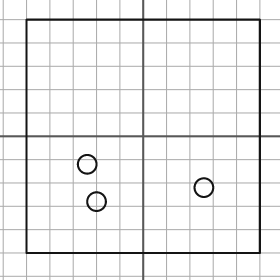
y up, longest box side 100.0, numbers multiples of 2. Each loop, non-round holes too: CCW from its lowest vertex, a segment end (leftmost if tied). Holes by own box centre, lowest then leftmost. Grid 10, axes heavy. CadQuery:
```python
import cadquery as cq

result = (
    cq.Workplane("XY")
    .moveTo(-50.0, -50.0)
    .lineTo(50.0, -50.0)
    .lineTo(50.0, 50.0)
    .lineTo(-50.0, 50.0)
    .close()
    .moveTo(-20.0, -28.0)
    .circle(4.0)
    .moveTo(26.0, -22.0)
    .circle(4.0)
    .moveTo(-24.0, -12.0)
    .circle(4.0)
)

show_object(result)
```